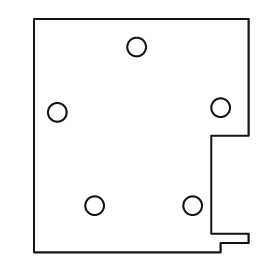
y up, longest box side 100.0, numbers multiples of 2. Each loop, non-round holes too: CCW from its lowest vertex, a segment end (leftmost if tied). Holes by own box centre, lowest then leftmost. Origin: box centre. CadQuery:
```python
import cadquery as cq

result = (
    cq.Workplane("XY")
    .moveTo(-46.0, -50.0)
    .lineTo(34.0, -50.0)
    .lineTo(34.0, -46.0)
    .lineTo(46.0, -46.0)
    .lineTo(46.0, -42.0)
    .lineTo(30.0, -42.0)
    .lineTo(30.0, 0.0)
    .lineTo(46.0, 0.0)
    .lineTo(46.0, 50.0)
    .lineTo(-46.0, 50.0)
    .close()
    .moveTo(-20.0, -30.0)
    .circle(4.0)
    .moveTo(22.0, -30.0)
    .circle(4.0)
    .moveTo(-36.0, 10.0)
    .circle(4.0)
    .moveTo(34.0, 12.0)
    .circle(4.0)
    .moveTo(-2.0, 38.0)
    .circle(4.0)
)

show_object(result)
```